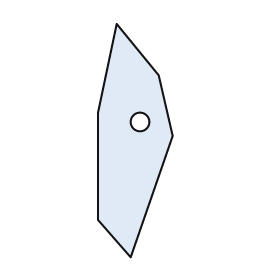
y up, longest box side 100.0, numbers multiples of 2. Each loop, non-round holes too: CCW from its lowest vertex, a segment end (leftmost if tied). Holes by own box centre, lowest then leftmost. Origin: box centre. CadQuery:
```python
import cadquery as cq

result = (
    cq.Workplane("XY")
    .moveTo(-2.0, -50.0)
    .lineTo(16.0, 2.0)
    .lineTo(10.0, 28.0)
    .lineTo(-8.0, 50.0)
    .lineTo(-16.0, 12.0)
    .lineTo(-16.0, -34.0)
    .close()
    .moveTo(2.0, 8.0)
    .circle(4.0)
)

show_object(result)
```